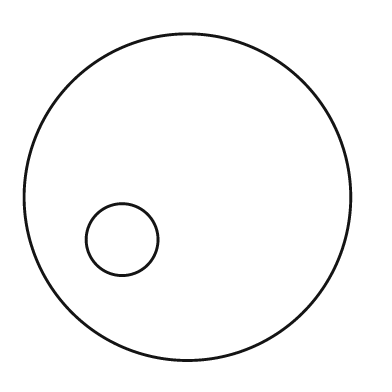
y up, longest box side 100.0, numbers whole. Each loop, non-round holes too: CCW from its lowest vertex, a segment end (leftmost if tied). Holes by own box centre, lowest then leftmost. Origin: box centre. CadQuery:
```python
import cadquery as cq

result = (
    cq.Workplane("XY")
    .moveTo(0.0, 0.0)
    .circle(50.0)
    .moveTo(-20.0, -13.0)
    .circle(11.0)
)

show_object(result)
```